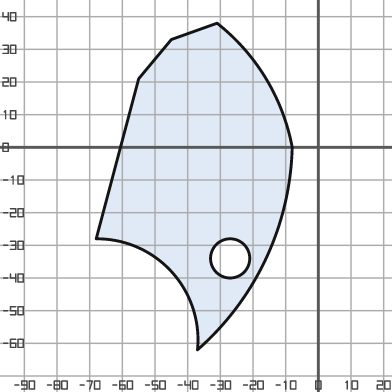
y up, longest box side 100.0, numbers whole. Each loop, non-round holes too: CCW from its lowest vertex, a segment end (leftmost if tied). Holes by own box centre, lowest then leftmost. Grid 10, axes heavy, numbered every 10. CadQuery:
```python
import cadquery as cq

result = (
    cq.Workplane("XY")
    .moveTo(-37.0, -62.0)
    .threePointArc((-16.0, -34.0), (-8.0, 0.0))
    .threePointArc((-16.0, 21.0), (-31.0, 38.0))
    .lineTo(-45.0, 33.0)
    .lineTo(-55.0, 21.0)
    .lineTo(-68.0, -28.0)
    .threePointArc((-45.0, -38.0), (-37.0, -62.0))
    .close()
    .moveTo(-27.0, -34.0)
    .circle(6.0)
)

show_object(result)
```